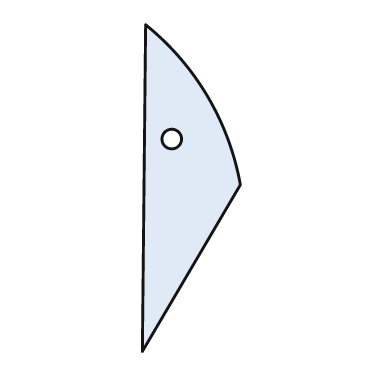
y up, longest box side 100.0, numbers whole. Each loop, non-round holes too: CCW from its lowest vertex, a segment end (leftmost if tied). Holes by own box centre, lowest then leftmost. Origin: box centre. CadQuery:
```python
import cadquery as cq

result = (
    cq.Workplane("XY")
    .moveTo(-15.0, -50.0)
    .lineTo(15.0, 1.0)
    .threePointArc((5.0, 28.0), (-14.0, 50.0))
    .close()
    .moveTo(-6.0, 15.0)
    .circle(3.0)
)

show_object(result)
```